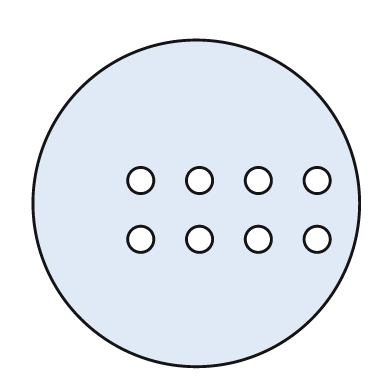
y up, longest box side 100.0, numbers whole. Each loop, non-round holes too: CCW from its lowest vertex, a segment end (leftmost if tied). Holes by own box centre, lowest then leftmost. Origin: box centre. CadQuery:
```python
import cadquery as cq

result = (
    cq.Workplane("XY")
    .moveTo(0.0, 0.0)
    .circle(50.0)
    .moveTo(-17.0, -11.0)
    .circle(4.0)
    .moveTo(1.0, -11.0)
    .circle(4.0)
    .moveTo(19.0, -11.0)
    .circle(4.0)
    .moveTo(37.0, -11.0)
    .circle(4.0)
    .moveTo(-17.0, 7.0)
    .circle(4.0)
    .moveTo(1.0, 7.0)
    .circle(4.0)
    .moveTo(19.0, 7.0)
    .circle(4.0)
    .moveTo(37.0, 7.0)
    .circle(4.0)
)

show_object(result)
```